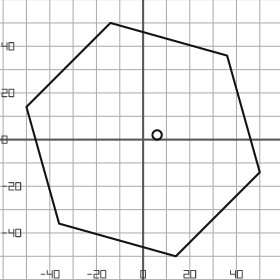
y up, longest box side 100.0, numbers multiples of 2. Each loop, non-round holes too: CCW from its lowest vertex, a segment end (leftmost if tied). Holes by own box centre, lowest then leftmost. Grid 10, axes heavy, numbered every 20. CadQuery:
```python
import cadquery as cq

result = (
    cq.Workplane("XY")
    .moveTo(14.0, -50.0)
    .lineTo(50.0, -14.0)
    .lineTo(36.0, 36.0)
    .lineTo(-14.0, 50.0)
    .lineTo(-50.0, 14.0)
    .lineTo(-36.0, -36.0)
    .close()
    .moveTo(6.0, 2.0)
    .circle(2.0)
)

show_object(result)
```